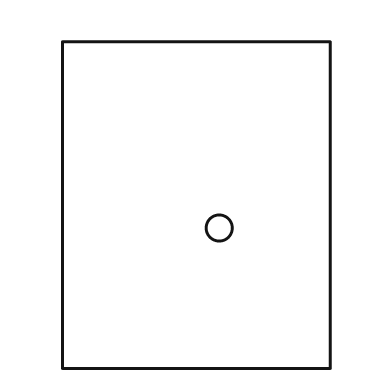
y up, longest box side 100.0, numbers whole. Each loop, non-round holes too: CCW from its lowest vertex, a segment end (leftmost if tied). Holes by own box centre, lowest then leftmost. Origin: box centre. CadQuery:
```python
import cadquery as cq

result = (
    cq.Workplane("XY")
    .moveTo(-41.0, -50.0)
    .lineTo(41.0, -50.0)
    .lineTo(41.0, 50.0)
    .lineTo(-41.0, 50.0)
    .close()
    .moveTo(7.0, -7.0)
    .circle(4.0)
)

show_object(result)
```